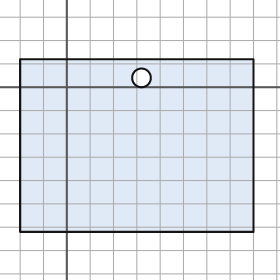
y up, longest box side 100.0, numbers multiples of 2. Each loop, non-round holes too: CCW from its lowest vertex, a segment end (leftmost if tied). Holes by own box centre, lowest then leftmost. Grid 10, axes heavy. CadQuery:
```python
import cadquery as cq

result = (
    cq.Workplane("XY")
    .moveTo(-20.0, -62.0)
    .lineTo(80.0, -62.0)
    .lineTo(80.0, 12.0)
    .lineTo(-20.0, 12.0)
    .close()
    .moveTo(32.0, 4.0)
    .circle(4.0)
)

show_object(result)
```